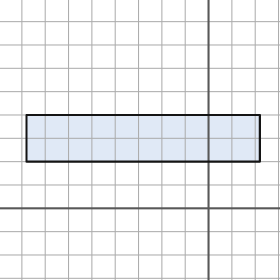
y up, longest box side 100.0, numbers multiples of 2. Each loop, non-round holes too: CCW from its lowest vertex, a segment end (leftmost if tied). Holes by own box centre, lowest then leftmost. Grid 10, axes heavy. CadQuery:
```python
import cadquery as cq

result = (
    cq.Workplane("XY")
    .moveTo(-78.0, 20.0)
    .lineTo(22.0, 20.0)
    .lineTo(22.0, 40.0)
    .lineTo(-78.0, 40.0)
    .close()
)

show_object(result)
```